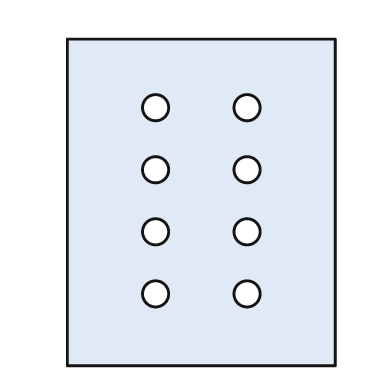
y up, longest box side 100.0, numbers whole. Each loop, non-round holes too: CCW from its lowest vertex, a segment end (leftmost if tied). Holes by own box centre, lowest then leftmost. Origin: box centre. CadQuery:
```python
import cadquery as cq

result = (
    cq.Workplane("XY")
    .moveTo(-41.0, -50.0)
    .lineTo(41.0, -50.0)
    .lineTo(41.0, 50.0)
    .lineTo(-41.0, 50.0)
    .close()
    .moveTo(-14.0, -28.0)
    .circle(4.0)
    .moveTo(14.0, -28.0)
    .circle(4.0)
    .moveTo(-14.0, -9.0)
    .circle(4.0)
    .moveTo(14.0, -9.0)
    .circle(4.0)
    .moveTo(-14.0, 10.0)
    .circle(4.0)
    .moveTo(14.0, 10.0)
    .circle(4.0)
    .moveTo(-14.0, 29.0)
    .circle(4.0)
    .moveTo(14.0, 29.0)
    .circle(4.0)
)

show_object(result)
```